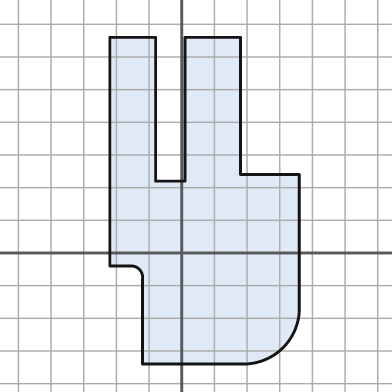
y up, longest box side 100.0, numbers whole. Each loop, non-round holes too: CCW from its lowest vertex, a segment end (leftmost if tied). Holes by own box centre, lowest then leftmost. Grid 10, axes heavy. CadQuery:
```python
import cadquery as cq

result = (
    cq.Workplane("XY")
    .moveTo(-12.0, -34.0)
    .lineTo(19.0, -34.0)
    .threePointArc((31.0, -29.0), (36.0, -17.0))
    .lineTo(36.0, 24.0)
    .lineTo(18.0, 24.0)
    .lineTo(18.0, 66.0)
    .lineTo(1.0, 66.0)
    .lineTo(1.0, 22.0)
    .lineTo(-8.0, 22.0)
    .lineTo(-8.0, 66.0)
    .lineTo(-22.0, 66.0)
    .lineTo(-22.0, -4.0)
    .lineTo(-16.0, -4.0)
    .threePointArc((-13.0, -5.0), (-12.0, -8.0))
    .close()
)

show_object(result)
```